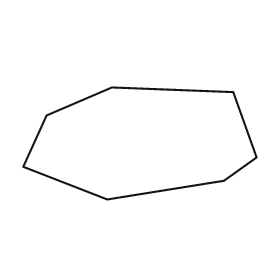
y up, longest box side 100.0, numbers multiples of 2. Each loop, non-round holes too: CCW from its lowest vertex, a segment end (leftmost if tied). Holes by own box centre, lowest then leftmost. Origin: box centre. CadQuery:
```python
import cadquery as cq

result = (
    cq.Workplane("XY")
    .moveTo(-14.0, -24.0)
    .lineTo(36.0, -16.0)
    .lineTo(50.0, -6.0)
    .lineTo(40.0, 22.0)
    .lineTo(-12.0, 24.0)
    .lineTo(-40.0, 12.0)
    .lineTo(-50.0, -10.0)
    .close()
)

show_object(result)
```